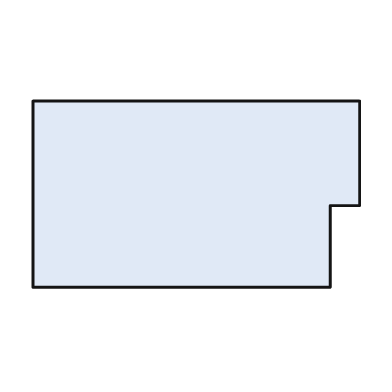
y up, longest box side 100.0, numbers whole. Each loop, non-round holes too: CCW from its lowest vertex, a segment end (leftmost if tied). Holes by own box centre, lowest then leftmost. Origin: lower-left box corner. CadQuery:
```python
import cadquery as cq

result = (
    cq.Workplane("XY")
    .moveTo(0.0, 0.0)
    .lineTo(91.0, 0.0)
    .lineTo(91.0, 25.0)
    .lineTo(100.0, 25.0)
    .lineTo(100.0, 57.0)
    .lineTo(0.0, 57.0)
    .close()
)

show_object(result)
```